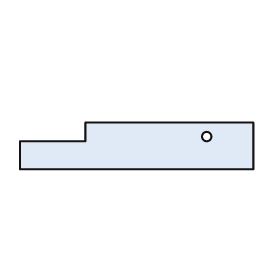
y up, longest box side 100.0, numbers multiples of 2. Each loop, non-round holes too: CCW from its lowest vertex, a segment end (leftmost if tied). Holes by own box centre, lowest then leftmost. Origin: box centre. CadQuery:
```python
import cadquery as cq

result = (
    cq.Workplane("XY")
    .moveTo(-50.0, -10.0)
    .lineTo(50.0, -10.0)
    .lineTo(50.0, 10.0)
    .lineTo(-22.0, 10.0)
    .lineTo(-22.0, 2.0)
    .lineTo(-50.0, 2.0)
    .close()
    .moveTo(30.0, 4.0)
    .circle(2.0)
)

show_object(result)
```